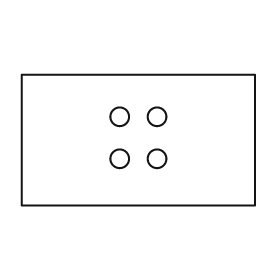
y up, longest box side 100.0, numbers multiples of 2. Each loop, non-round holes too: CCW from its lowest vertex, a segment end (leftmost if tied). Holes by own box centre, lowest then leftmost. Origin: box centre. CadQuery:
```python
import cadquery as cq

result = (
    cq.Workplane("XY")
    .moveTo(-50.0, -28.0)
    .lineTo(50.0, -28.0)
    .lineTo(50.0, 28.0)
    .lineTo(-50.0, 28.0)
    .close()
    .moveTo(-8.0, -8.0)
    .circle(4.0)
    .moveTo(8.0, -8.0)
    .circle(4.0)
    .moveTo(-8.0, 10.0)
    .circle(4.0)
    .moveTo(8.0, 10.0)
    .circle(4.0)
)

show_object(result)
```